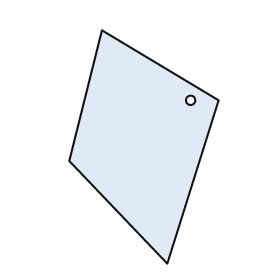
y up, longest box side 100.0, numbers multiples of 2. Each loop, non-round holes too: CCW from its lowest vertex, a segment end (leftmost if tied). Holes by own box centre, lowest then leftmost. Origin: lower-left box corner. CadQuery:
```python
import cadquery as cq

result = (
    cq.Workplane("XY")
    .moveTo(42.0, 0.0)
    .lineTo(64.0, 70.0)
    .lineTo(14.0, 100.0)
    .lineTo(0.0, 44.0)
    .close()
    .moveTo(52.0, 70.0)
    .circle(2.0)
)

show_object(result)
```